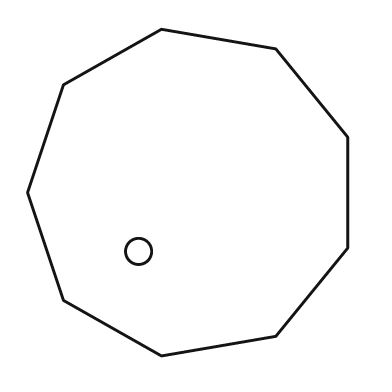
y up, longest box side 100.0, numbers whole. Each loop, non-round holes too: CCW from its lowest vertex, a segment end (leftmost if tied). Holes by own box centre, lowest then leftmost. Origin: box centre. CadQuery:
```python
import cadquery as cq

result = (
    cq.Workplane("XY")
    .moveTo(-8.0, -50.0)
    .lineTo(27.0, -44.0)
    .lineTo(49.0, -17.0)
    .lineTo(49.0, 17.0)
    .lineTo(27.0, 44.0)
    .lineTo(-8.0, 50.0)
    .lineTo(-38.0, 33.0)
    .lineTo(-49.0, 0.0)
    .lineTo(-38.0, -33.0)
    .close()
    .moveTo(-15.0, -18.0)
    .circle(4.0)
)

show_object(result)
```